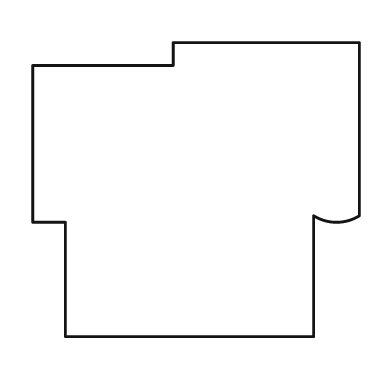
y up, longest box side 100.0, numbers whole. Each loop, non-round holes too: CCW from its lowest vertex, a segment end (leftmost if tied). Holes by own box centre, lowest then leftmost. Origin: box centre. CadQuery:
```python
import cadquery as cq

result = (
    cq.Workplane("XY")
    .moveTo(-40.0, -45.0)
    .lineTo(36.0, -45.0)
    .lineTo(36.0, -8.0)
    .threePointArc((43.0, -10.0), (50.0, -8.0))
    .lineTo(50.0, 45.0)
    .lineTo(-7.0, 45.0)
    .lineTo(-7.0, 38.0)
    .lineTo(-50.0, 38.0)
    .lineTo(-50.0, -10.0)
    .lineTo(-40.0, -10.0)
    .close()
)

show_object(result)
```